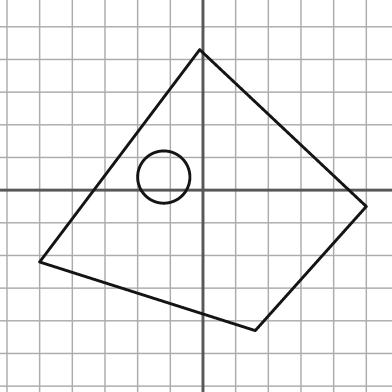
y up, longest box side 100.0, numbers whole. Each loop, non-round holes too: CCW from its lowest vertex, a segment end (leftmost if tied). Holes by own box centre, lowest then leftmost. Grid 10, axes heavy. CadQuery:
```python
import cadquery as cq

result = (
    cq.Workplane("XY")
    .moveTo(16.0, -43.0)
    .lineTo(50.0, -5.0)
    .lineTo(-1.0, 43.0)
    .lineTo(-50.0, -22.0)
    .close()
    .moveTo(-12.0, 4.0)
    .circle(8.0)
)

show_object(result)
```